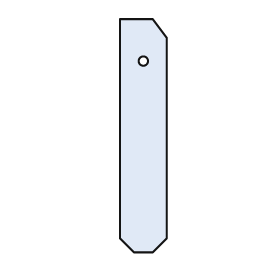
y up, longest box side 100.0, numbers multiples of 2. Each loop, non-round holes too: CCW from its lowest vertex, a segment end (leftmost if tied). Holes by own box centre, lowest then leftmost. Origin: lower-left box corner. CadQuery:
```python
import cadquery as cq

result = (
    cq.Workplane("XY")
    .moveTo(6.0, 0.0)
    .lineTo(14.0, 0.0)
    .lineTo(20.0, 6.0)
    .lineTo(20.0, 92.0)
    .lineTo(14.0, 100.0)
    .lineTo(0.0, 100.0)
    .lineTo(0.0, 6.0)
    .close()
    .moveTo(10.0, 82.0)
    .circle(2.0)
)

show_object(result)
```